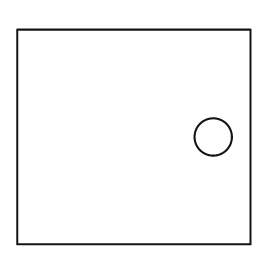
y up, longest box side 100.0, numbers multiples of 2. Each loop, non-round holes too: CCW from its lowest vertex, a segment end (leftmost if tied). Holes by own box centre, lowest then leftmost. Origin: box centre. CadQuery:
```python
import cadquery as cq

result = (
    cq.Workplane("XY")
    .moveTo(-50.0, -46.0)
    .lineTo(50.0, -46.0)
    .lineTo(50.0, 46.0)
    .lineTo(-50.0, 46.0)
    .close()
    .moveTo(34.0, 0.0)
    .circle(8.0)
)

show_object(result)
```